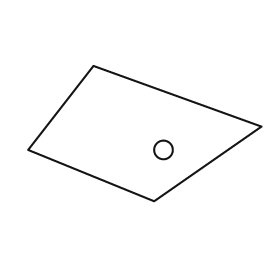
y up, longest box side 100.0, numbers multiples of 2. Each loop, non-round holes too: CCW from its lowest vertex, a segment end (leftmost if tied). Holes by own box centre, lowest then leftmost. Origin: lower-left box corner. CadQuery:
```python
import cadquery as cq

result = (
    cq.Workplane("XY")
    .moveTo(54.0, 0.0)
    .lineTo(100.0, 32.0)
    .lineTo(28.0, 58.0)
    .lineTo(0.0, 22.0)
    .close()
    .moveTo(58.0, 22.0)
    .circle(4.0)
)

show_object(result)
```